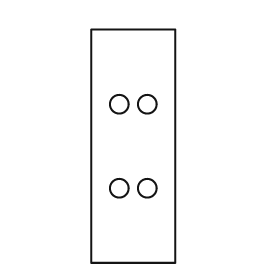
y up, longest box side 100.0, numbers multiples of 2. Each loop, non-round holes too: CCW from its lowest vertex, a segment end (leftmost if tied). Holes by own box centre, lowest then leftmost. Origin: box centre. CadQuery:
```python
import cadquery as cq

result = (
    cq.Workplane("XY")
    .moveTo(-18.0, -50.0)
    .lineTo(18.0, -50.0)
    .lineTo(18.0, 50.0)
    .lineTo(-18.0, 50.0)
    .close()
    .moveTo(-6.0, -18.0)
    .circle(4.0)
    .moveTo(6.0, -18.0)
    .circle(4.0)
    .moveTo(-6.0, 18.0)
    .circle(4.0)
    .moveTo(6.0, 18.0)
    .circle(4.0)
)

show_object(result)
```